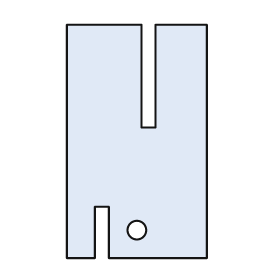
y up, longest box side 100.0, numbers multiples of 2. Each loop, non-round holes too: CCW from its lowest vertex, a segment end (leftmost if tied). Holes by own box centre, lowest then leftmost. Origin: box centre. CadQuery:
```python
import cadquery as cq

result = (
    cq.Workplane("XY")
    .moveTo(-30.0, -50.0)
    .lineTo(-18.0, -50.0)
    .lineTo(-18.0, -28.0)
    .lineTo(-12.0, -28.0)
    .lineTo(-12.0, -50.0)
    .lineTo(30.0, -50.0)
    .lineTo(30.0, 50.0)
    .lineTo(8.0, 50.0)
    .lineTo(8.0, 6.0)
    .lineTo(2.0, 6.0)
    .lineTo(2.0, 50.0)
    .lineTo(-30.0, 50.0)
    .close()
    .moveTo(0.0, -38.0)
    .circle(4.0)
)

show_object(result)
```